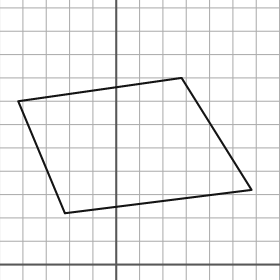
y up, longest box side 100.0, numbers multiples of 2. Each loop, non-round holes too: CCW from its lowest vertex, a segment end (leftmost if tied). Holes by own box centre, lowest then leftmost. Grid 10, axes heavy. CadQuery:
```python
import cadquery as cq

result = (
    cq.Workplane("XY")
    .moveTo(-22.0, 22.0)
    .lineTo(58.0, 32.0)
    .lineTo(28.0, 80.0)
    .lineTo(-42.0, 70.0)
    .close()
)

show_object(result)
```